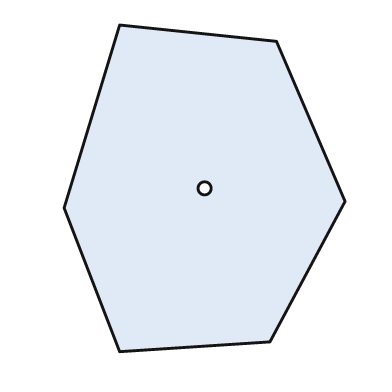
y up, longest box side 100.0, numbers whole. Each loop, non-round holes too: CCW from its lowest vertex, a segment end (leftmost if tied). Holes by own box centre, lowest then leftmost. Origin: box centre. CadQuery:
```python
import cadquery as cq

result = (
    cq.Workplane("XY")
    .moveTo(-26.0, -50.0)
    .lineTo(20.0, -47.0)
    .lineTo(43.0, -4.0)
    .lineTo(22.0, 45.0)
    .lineTo(-26.0, 50.0)
    .lineTo(-43.0, -6.0)
    .close()
    .moveTo(0.0, 0.0)
    .circle(2.0)
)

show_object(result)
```